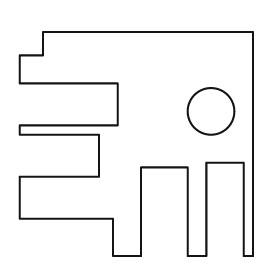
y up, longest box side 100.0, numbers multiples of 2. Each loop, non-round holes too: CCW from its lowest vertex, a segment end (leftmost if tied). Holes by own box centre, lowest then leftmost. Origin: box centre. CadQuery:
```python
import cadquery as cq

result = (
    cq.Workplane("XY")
    .moveTo(-10.0, -48.0)
    .lineTo(2.0, -48.0)
    .lineTo(2.0, -10.0)
    .lineTo(22.0, -10.0)
    .lineTo(22.0, -48.0)
    .lineTo(30.0, -48.0)
    .lineTo(30.0, -8.0)
    .lineTo(46.0, -8.0)
    .lineTo(46.0, -48.0)
    .lineTo(50.0, -48.0)
    .lineTo(50.0, 48.0)
    .lineTo(-40.0, 48.0)
    .lineTo(-40.0, 38.0)
    .lineTo(-50.0, 38.0)
    .lineTo(-50.0, 26.0)
    .lineTo(-8.0, 26.0)
    .lineTo(-8.0, 8.0)
    .lineTo(-50.0, 8.0)
    .lineTo(-50.0, 4.0)
    .lineTo(-16.0, 4.0)
    .lineTo(-16.0, -14.0)
    .lineTo(-50.0, -14.0)
    .lineTo(-50.0, -32.0)
    .lineTo(-10.0, -32.0)
    .close()
    .moveTo(32.0, 14.0)
    .circle(10.0)
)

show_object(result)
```